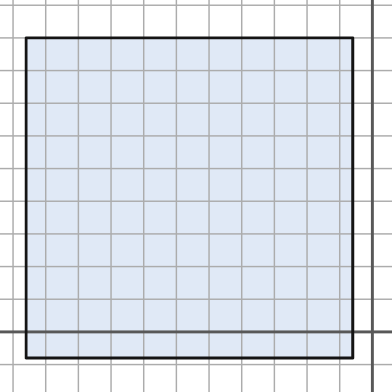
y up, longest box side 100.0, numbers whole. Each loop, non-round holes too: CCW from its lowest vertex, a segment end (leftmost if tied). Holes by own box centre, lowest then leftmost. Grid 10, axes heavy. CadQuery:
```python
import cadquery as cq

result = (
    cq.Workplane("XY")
    .moveTo(-106.0, -8.0)
    .lineTo(-6.0, -8.0)
    .lineTo(-6.0, 90.0)
    .lineTo(-106.0, 90.0)
    .close()
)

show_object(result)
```